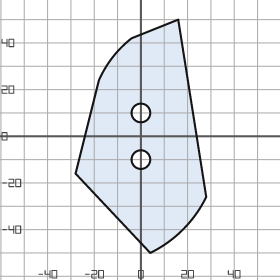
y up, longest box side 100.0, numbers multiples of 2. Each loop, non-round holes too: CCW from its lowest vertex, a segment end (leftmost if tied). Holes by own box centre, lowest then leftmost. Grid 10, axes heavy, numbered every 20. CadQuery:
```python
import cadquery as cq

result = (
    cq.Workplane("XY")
    .moveTo(4.0, -50.0)
    .threePointArc((18.0, -40.0), (28.0, -26.0))
    .lineTo(16.0, 50.0)
    .lineTo(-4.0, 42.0)
    .threePointArc((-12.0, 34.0), (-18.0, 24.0))
    .lineTo(-28.0, -16.0)
    .close()
    .moveTo(0.0, -10.0)
    .circle(4.0)
    .moveTo(0.0, 10.0)
    .circle(4.0)
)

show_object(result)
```